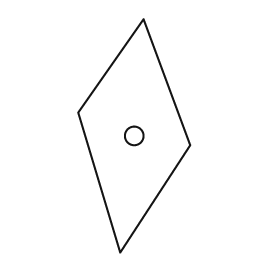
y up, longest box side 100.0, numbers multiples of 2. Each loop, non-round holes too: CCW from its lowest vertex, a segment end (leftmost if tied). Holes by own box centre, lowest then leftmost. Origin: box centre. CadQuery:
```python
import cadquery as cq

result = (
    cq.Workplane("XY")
    .moveTo(-6.0, -50.0)
    .lineTo(24.0, -4.0)
    .lineTo(4.0, 50.0)
    .lineTo(-24.0, 10.0)
    .close()
    .moveTo(0.0, 0.0)
    .circle(4.0)
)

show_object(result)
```